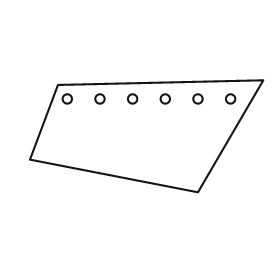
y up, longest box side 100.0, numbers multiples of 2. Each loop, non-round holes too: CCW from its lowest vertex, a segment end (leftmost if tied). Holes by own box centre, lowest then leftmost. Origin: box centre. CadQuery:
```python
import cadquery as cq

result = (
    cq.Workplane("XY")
    .moveTo(22.0, -24.0)
    .lineTo(50.0, 24.0)
    .lineTo(-38.0, 22.0)
    .lineTo(-50.0, -10.0)
    .close()
    .moveTo(-34.0, 16.0)
    .circle(2.0)
    .moveTo(-20.0, 16.0)
    .circle(2.0)
    .moveTo(-6.0, 16.0)
    .circle(2.0)
    .moveTo(8.0, 16.0)
    .circle(2.0)
    .moveTo(22.0, 16.0)
    .circle(2.0)
    .moveTo(36.0, 16.0)
    .circle(2.0)
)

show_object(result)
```